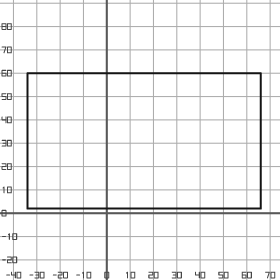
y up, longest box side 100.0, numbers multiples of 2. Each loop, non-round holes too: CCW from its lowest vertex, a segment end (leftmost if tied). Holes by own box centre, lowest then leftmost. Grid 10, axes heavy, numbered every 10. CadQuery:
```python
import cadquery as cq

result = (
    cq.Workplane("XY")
    .moveTo(-34.0, 2.0)
    .lineTo(66.0, 2.0)
    .lineTo(66.0, 60.0)
    .lineTo(-34.0, 60.0)
    .close()
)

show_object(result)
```